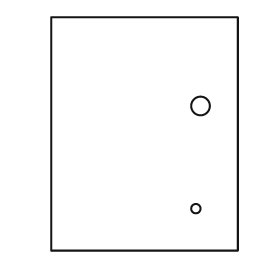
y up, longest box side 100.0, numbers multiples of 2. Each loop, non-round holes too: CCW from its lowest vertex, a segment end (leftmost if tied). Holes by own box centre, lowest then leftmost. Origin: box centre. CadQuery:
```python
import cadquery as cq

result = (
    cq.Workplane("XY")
    .moveTo(-40.0, -50.0)
    .lineTo(40.0, -50.0)
    .lineTo(40.0, 50.0)
    .lineTo(-40.0, 50.0)
    .close()
    .moveTo(22.0, -32.0)
    .circle(2.0)
    .moveTo(24.0, 12.0)
    .circle(4.0)
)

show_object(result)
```